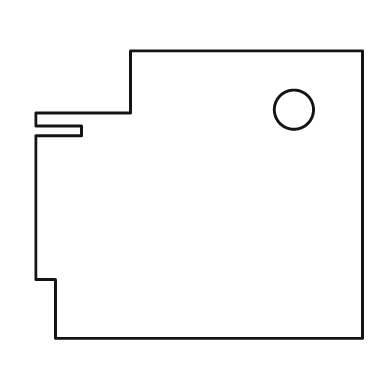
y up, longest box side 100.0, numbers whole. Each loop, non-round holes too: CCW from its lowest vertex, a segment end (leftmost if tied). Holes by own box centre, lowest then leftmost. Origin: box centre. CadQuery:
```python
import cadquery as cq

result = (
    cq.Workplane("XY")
    .moveTo(-44.0, -44.0)
    .lineTo(50.0, -44.0)
    .lineTo(50.0, 44.0)
    .lineTo(-21.0, 44.0)
    .lineTo(-21.0, 25.0)
    .lineTo(-50.0, 25.0)
    .lineTo(-50.0, 21.0)
    .lineTo(-36.0, 21.0)
    .lineTo(-36.0, 18.0)
    .lineTo(-50.0, 18.0)
    .lineTo(-50.0, -26.0)
    .lineTo(-44.0, -26.0)
    .close()
    .moveTo(29.0, 26.0)
    .circle(6.0)
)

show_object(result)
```